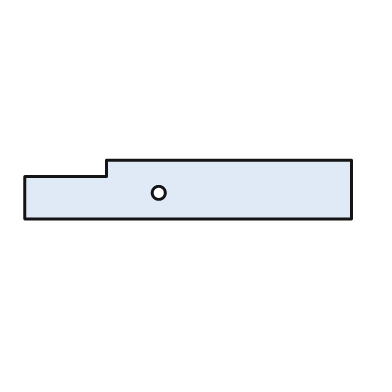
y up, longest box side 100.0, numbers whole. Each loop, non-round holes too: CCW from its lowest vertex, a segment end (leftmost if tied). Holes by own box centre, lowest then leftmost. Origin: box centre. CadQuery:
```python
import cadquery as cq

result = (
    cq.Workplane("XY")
    .moveTo(-50.0, -9.0)
    .lineTo(50.0, -9.0)
    .lineTo(50.0, 9.0)
    .lineTo(-25.0, 9.0)
    .lineTo(-25.0, 4.0)
    .lineTo(-50.0, 4.0)
    .close()
    .moveTo(-9.0, -1.0)
    .circle(2.0)
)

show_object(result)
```